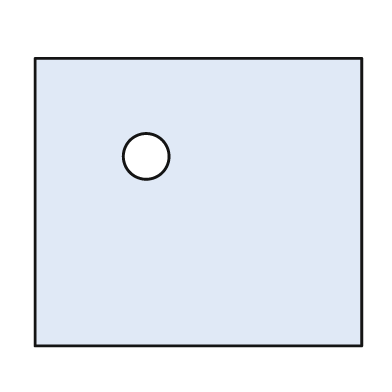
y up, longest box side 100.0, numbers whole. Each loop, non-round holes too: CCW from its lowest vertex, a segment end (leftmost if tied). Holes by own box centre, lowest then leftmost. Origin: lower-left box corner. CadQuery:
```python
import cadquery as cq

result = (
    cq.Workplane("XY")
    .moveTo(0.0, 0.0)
    .lineTo(100.0, 0.0)
    .lineTo(100.0, 88.0)
    .lineTo(0.0, 88.0)
    .close()
    .moveTo(34.0, 58.0)
    .circle(7.0)
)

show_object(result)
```